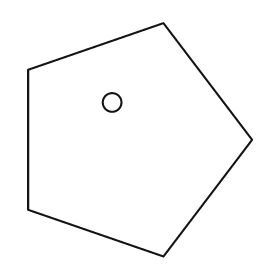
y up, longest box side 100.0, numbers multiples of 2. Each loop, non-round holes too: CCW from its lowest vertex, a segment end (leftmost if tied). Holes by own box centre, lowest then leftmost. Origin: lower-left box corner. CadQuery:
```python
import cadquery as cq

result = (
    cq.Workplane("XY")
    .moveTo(58.0, 0.0)
    .lineTo(96.0, 50.0)
    .lineTo(58.0, 100.0)
    .lineTo(0.0, 80.0)
    .lineTo(0.0, 20.0)
    .close()
    .moveTo(36.0, 66.0)
    .circle(4.0)
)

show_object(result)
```